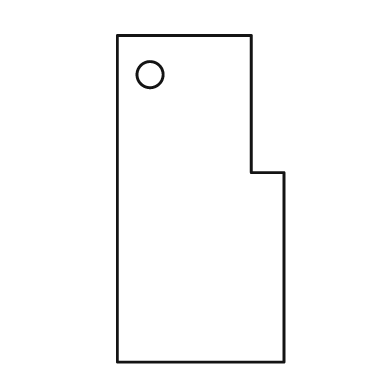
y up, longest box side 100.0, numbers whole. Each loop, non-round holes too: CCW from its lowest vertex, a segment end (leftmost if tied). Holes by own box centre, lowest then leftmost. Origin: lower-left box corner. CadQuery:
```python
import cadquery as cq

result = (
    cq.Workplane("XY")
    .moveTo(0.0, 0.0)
    .lineTo(51.0, 0.0)
    .lineTo(51.0, 58.0)
    .lineTo(41.0, 58.0)
    .lineTo(41.0, 100.0)
    .lineTo(0.0, 100.0)
    .close()
    .moveTo(10.0, 88.0)
    .circle(4.0)
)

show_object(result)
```